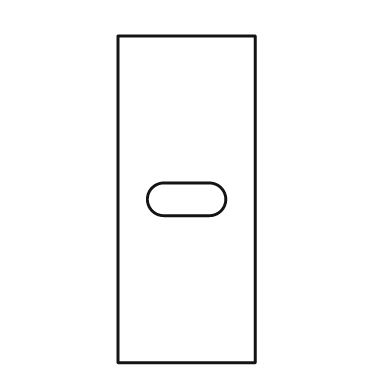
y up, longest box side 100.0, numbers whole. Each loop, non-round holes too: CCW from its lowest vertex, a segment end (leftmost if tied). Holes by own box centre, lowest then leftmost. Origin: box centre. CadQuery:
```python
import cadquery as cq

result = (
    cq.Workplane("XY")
    .moveTo(-21.0, -50.0)
    .lineTo(21.0, -50.0)
    .lineTo(21.0, 50.0)
    .lineTo(-21.0, 50.0)
    .close()
    .moveTo(-7.0, -5.0)
    .lineTo(7.0, -5.0)
    .threePointArc((12.0, 0.0), (7.0, 5.0))
    .lineTo(-7.0, 5.0)
    .threePointArc((-12.0, 0.0), (-7.0, -5.0))
    .close()
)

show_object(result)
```